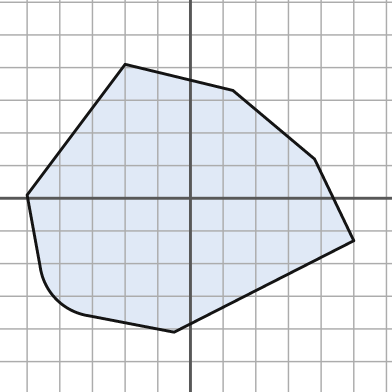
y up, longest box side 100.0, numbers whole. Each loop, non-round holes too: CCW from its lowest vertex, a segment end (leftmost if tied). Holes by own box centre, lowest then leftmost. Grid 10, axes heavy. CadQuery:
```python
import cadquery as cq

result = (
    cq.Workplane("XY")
    .moveTo(-5.0, -41.0)
    .lineTo(50.0, -13.0)
    .lineTo(38.0, 12.0)
    .lineTo(13.0, 33.0)
    .lineTo(-20.0, 41.0)
    .lineTo(-50.0, 1.0)
    .lineTo(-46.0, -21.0)
    .threePointArc((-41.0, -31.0), (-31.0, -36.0))
    .close()
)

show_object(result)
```